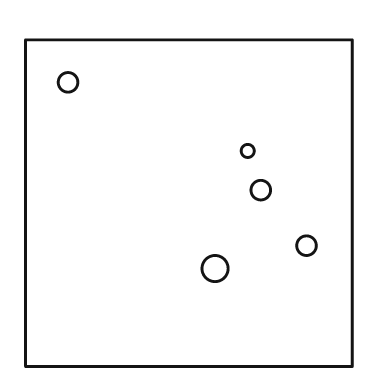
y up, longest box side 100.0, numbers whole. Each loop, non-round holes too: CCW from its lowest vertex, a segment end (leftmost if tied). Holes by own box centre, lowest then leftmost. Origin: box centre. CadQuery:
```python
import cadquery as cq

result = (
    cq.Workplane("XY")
    .moveTo(-50.0, -50.0)
    .lineTo(50.0, -50.0)
    .lineTo(50.0, 50.0)
    .lineTo(-50.0, 50.0)
    .close()
    .moveTo(8.0, -20.0)
    .circle(4.0)
    .moveTo(36.0, -13.0)
    .circle(3.0)
    .moveTo(22.0, 4.0)
    .circle(3.0)
    .moveTo(18.0, 16.0)
    .circle(2.0)
    .moveTo(-37.0, 37.0)
    .circle(3.0)
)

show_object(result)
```